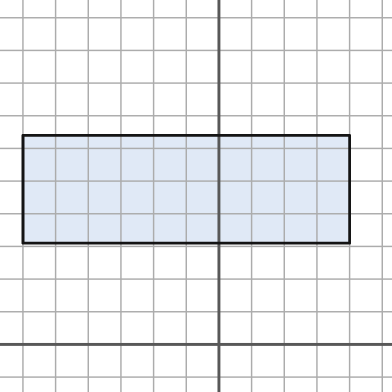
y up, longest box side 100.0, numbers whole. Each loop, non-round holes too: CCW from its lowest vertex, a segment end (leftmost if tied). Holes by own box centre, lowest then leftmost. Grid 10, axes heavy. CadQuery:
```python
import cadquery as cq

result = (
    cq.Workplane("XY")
    .moveTo(-60.0, 31.0)
    .lineTo(40.0, 31.0)
    .lineTo(40.0, 64.0)
    .lineTo(-60.0, 64.0)
    .close()
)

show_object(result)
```